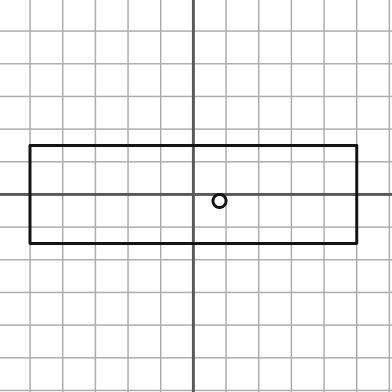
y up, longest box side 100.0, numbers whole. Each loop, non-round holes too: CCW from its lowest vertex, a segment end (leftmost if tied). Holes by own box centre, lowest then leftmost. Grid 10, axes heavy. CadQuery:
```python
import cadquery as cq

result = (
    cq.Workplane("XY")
    .moveTo(-50.0, -15.0)
    .lineTo(50.0, -15.0)
    .lineTo(50.0, 15.0)
    .lineTo(-50.0, 15.0)
    .close()
    .moveTo(8.0, -2.0)
    .circle(2.0)
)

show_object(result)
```